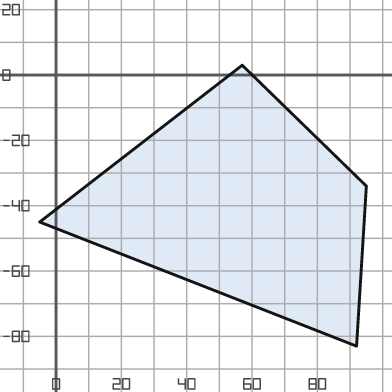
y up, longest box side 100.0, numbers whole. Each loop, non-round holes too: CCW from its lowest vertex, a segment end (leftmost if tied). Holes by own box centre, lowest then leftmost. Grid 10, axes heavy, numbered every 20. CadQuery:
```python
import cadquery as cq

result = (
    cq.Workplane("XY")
    .moveTo(92.0, -83.0)
    .lineTo(95.0, -34.0)
    .lineTo(57.0, 3.0)
    .lineTo(-5.0, -45.0)
    .close()
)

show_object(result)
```